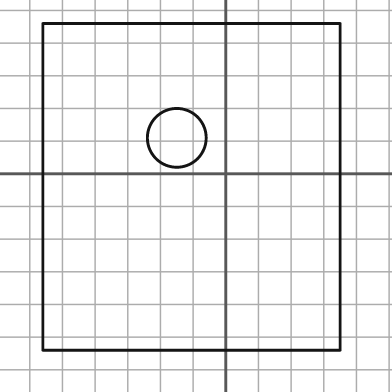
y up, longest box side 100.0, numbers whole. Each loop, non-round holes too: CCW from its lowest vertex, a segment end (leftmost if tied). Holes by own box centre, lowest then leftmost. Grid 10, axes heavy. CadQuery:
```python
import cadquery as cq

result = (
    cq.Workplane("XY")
    .moveTo(-56.0, -54.0)
    .lineTo(35.0, -54.0)
    .lineTo(35.0, 46.0)
    .lineTo(-56.0, 46.0)
    .close()
    .moveTo(-15.0, 11.0)
    .circle(9.0)
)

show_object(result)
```